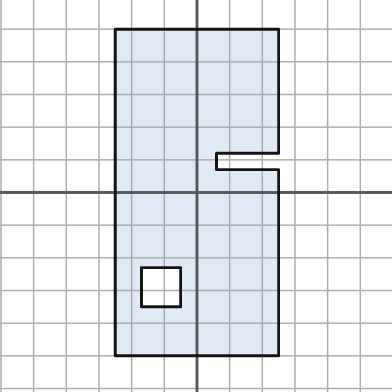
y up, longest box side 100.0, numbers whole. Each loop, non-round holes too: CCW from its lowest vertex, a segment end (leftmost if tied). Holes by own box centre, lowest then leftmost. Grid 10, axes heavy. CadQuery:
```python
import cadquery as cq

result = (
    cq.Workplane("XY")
    .moveTo(-25.0, -50.0)
    .lineTo(25.0, -50.0)
    .lineTo(25.0, 7.0)
    .lineTo(6.0, 7.0)
    .lineTo(6.0, 12.0)
    .lineTo(25.0, 12.0)
    .lineTo(25.0, 50.0)
    .lineTo(-25.0, 50.0)
    .close()
    .moveTo(-17.0, -35.0)
    .lineTo(-5.0, -35.0)
    .lineTo(-5.0, -23.0)
    .lineTo(-17.0, -23.0)
    .close()
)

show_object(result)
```